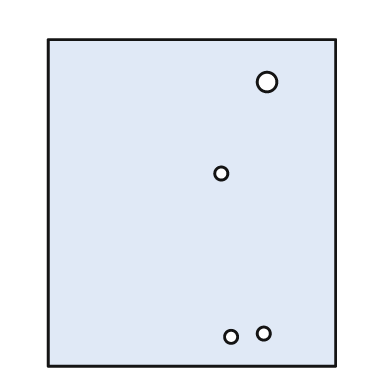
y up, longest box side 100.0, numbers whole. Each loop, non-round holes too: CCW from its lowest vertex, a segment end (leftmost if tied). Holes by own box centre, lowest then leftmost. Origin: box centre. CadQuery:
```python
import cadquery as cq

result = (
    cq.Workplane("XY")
    .moveTo(-44.0, -50.0)
    .lineTo(44.0, -50.0)
    .lineTo(44.0, 50.0)
    .lineTo(-44.0, 50.0)
    .close()
    .moveTo(12.0, -41.0)
    .circle(2.0)
    .moveTo(22.0, -40.0)
    .circle(2.0)
    .moveTo(9.0, 9.0)
    .circle(2.0)
    .moveTo(23.0, 37.0)
    .circle(3.0)
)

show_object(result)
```